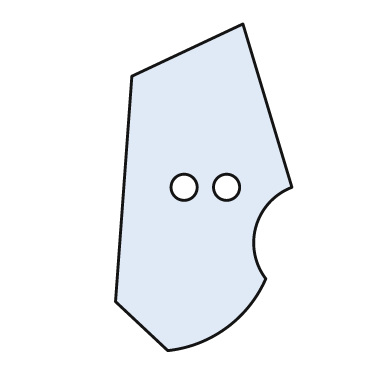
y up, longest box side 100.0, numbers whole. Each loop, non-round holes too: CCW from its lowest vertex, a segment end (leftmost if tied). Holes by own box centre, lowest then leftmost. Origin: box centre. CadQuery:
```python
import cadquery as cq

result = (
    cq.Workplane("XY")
    .moveTo(-11.0, -50.0)
    .threePointArc((7.0, -43.0), (19.0, -28.0))
    .threePointArc((16.0, -12.0), (27.0, 0.0))
    .lineTo(12.0, 50.0)
    .lineTo(-22.0, 34.0)
    .lineTo(-27.0, -35.0)
    .close()
    .moveTo(-6.0, 0.0)
    .circle(4.0)
    .moveTo(7.0, 0.0)
    .circle(4.0)
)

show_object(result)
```